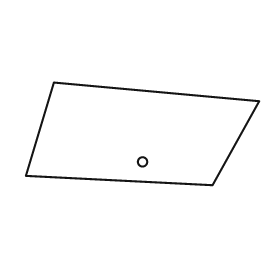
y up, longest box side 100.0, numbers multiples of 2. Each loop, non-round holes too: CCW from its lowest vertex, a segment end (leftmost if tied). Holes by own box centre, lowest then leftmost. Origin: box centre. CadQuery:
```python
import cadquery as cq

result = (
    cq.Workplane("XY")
    .moveTo(30.0, -22.0)
    .lineTo(50.0, 14.0)
    .lineTo(-38.0, 22.0)
    .lineTo(-50.0, -18.0)
    .close()
    .moveTo(0.0, -12.0)
    .circle(2.0)
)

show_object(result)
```